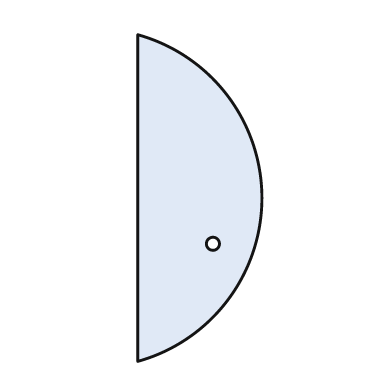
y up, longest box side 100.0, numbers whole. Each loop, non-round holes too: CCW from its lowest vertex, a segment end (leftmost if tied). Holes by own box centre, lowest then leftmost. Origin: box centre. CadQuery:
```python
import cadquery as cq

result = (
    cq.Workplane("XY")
    .moveTo(-19.0, -50.0)
    .threePointArc((19.0, 0.0), (-19.0, 50.0))
    .close()
    .moveTo(4.0, -14.0)
    .circle(2.0)
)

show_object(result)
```